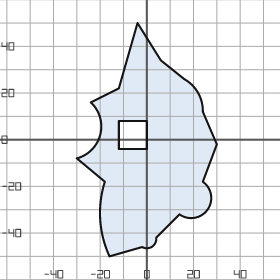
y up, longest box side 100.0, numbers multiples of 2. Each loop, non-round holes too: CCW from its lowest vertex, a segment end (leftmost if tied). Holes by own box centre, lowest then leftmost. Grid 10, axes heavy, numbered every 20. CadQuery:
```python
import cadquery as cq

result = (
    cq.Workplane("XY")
    .moveTo(-16.0, -50.0)
    .lineTo(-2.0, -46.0)
    .threePointArc((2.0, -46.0), (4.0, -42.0))
    .lineTo(14.0, -32.0)
    .threePointArc((26.0, -30.0), (24.0, -18.0))
    .lineTo(30.0, -2.0)
    .lineTo(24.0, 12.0)
    .threePointArc((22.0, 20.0), (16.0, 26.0))
    .lineTo(6.0, 34.0)
    .lineTo(-4.0, 50.0)
    .lineTo(-12.0, 22.0)
    .lineTo(-24.0, 16.0)
    .threePointArc((-20.0, 2.0), (-30.0, -8.0))
    .lineTo(-18.0, -18.0)
    .threePointArc((-20.0, -34.0), (-16.0, -50.0))
    .close()
    .moveTo(-12.0, -4.0)
    .lineTo(0.0, -4.0)
    .lineTo(0.0, 8.0)
    .lineTo(-12.0, 8.0)
    .close()
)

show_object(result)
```